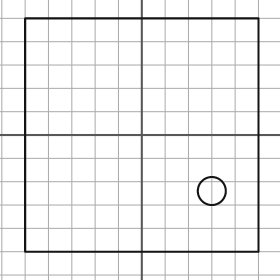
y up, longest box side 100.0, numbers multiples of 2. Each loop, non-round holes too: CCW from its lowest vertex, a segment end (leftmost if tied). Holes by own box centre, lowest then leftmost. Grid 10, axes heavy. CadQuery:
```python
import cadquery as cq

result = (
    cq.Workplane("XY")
    .moveTo(-50.0, -50.0)
    .lineTo(50.0, -50.0)
    .lineTo(50.0, 50.0)
    .lineTo(-50.0, 50.0)
    .close()
    .moveTo(30.0, -24.0)
    .circle(6.0)
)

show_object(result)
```